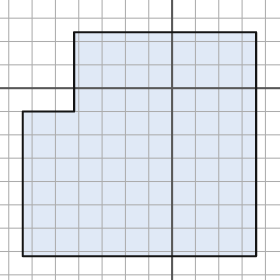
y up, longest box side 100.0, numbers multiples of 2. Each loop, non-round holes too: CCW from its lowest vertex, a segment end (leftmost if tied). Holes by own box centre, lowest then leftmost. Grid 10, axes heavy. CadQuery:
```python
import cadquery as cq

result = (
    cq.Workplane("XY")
    .moveTo(-64.0, -72.0)
    .lineTo(36.0, -72.0)
    .lineTo(36.0, 24.0)
    .lineTo(-42.0, 24.0)
    .lineTo(-42.0, -10.0)
    .lineTo(-64.0, -10.0)
    .close()
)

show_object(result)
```